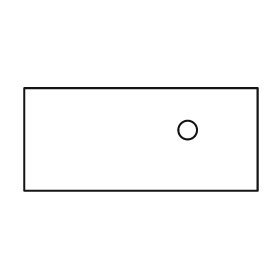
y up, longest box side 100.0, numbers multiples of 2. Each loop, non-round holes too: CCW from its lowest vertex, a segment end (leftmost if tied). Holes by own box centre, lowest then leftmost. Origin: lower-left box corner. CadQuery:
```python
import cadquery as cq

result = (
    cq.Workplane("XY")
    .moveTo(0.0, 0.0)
    .lineTo(100.0, 0.0)
    .lineTo(100.0, 44.0)
    .lineTo(0.0, 44.0)
    .close()
    .moveTo(70.0, 26.0)
    .circle(4.0)
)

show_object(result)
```